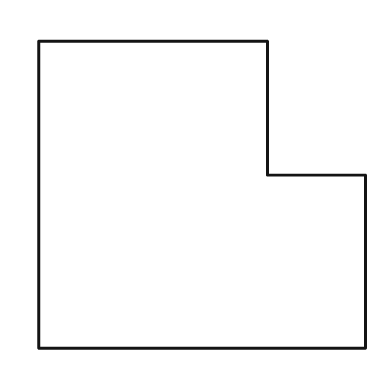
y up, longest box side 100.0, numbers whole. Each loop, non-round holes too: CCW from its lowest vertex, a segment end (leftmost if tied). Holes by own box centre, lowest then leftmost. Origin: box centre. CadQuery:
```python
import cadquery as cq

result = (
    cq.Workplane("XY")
    .moveTo(-50.0, -47.0)
    .lineTo(50.0, -47.0)
    .lineTo(50.0, 6.0)
    .lineTo(20.0, 6.0)
    .lineTo(20.0, 47.0)
    .lineTo(-50.0, 47.0)
    .close()
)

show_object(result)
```